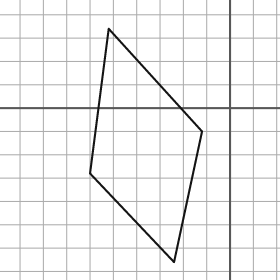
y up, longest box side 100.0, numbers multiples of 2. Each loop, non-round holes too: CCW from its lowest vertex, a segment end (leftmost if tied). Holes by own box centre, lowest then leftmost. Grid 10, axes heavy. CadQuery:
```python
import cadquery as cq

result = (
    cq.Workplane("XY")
    .moveTo(-24.0, -66.0)
    .lineTo(-12.0, -10.0)
    .lineTo(-52.0, 34.0)
    .lineTo(-60.0, -28.0)
    .close()
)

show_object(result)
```